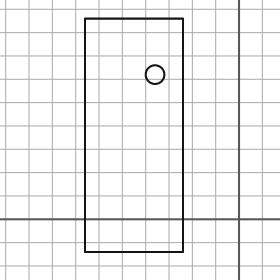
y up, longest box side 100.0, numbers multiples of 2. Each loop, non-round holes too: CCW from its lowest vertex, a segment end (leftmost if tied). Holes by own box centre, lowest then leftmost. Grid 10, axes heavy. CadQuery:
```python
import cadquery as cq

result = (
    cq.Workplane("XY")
    .moveTo(-66.0, -14.0)
    .lineTo(-24.0, -14.0)
    .lineTo(-24.0, 86.0)
    .lineTo(-66.0, 86.0)
    .close()
    .moveTo(-36.0, 62.0)
    .circle(4.0)
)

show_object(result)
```